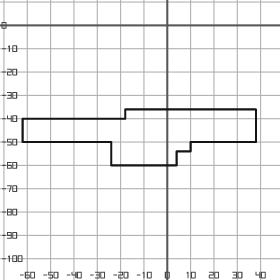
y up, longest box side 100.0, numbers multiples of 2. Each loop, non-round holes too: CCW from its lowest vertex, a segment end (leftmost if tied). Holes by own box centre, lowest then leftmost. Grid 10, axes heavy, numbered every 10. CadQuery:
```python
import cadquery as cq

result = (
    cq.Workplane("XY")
    .moveTo(-24.0, -60.0)
    .lineTo(4.0, -60.0)
    .lineTo(4.0, -54.0)
    .lineTo(10.0, -54.0)
    .lineTo(10.0, -50.0)
    .lineTo(38.0, -50.0)
    .lineTo(38.0, -36.0)
    .lineTo(-18.0, -36.0)
    .lineTo(-18.0, -40.0)
    .lineTo(-62.0, -40.0)
    .lineTo(-62.0, -50.0)
    .lineTo(-24.0, -50.0)
    .close()
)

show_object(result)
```